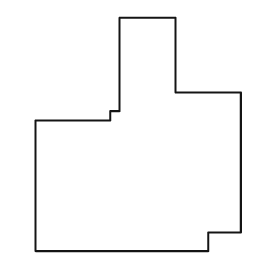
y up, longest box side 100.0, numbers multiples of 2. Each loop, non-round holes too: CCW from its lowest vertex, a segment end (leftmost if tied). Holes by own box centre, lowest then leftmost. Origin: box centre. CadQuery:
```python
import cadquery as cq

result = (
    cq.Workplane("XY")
    .moveTo(-44.0, -50.0)
    .lineTo(30.0, -50.0)
    .lineTo(30.0, -42.0)
    .lineTo(44.0, -42.0)
    .lineTo(44.0, 18.0)
    .lineTo(16.0, 18.0)
    .lineTo(16.0, 50.0)
    .lineTo(-8.0, 50.0)
    .lineTo(-8.0, 10.0)
    .lineTo(-12.0, 10.0)
    .lineTo(-12.0, 6.0)
    .lineTo(-44.0, 6.0)
    .close()
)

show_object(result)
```